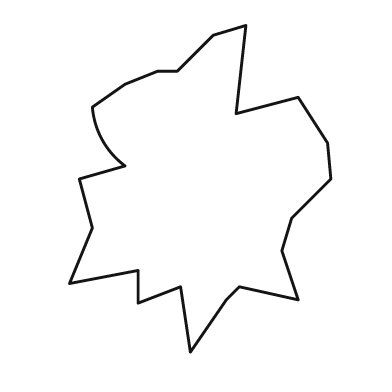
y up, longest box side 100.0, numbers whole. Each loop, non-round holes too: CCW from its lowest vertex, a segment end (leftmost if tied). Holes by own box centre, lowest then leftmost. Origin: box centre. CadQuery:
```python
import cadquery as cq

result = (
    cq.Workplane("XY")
    .moveTo(-3.0, -50.0)
    .lineTo(8.0, -34.0)
    .lineTo(12.0, -30.0)
    .lineTo(30.0, -34.0)
    .lineTo(25.0, -19.0)
    .lineTo(28.0, -9.0)
    .lineTo(40.0, 3.0)
    .lineTo(39.0, 14.0)
    .lineTo(30.0, 28.0)
    .lineTo(11.0, 23.0)
    .lineTo(14.0, 50.0)
    .lineTo(4.0, 47.0)
    .lineTo(-7.0, 36.0)
    .lineTo(-13.0, 36.0)
    .lineTo(-23.0, 32.0)
    .lineTo(-33.0, 25.0)
    .threePointArc((-30.0, 15.0), (-23.0, 7.0))
    .lineTo(-37.0, 3.0)
    .lineTo(-33.0, -12.0)
    .lineTo(-40.0, -29.0)
    .lineTo(-19.0, -25.0)
    .lineTo(-19.0, -35.0)
    .lineTo(-6.0, -30.0)
    .close()
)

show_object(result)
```